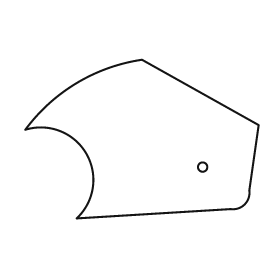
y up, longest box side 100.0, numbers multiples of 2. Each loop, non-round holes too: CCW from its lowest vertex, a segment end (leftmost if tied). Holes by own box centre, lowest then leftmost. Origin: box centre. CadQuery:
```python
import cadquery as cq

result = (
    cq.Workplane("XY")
    .moveTo(-28.0, -34.0)
    .lineTo(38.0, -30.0)
    .threePointArc((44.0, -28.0), (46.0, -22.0))
    .lineTo(50.0, 6.0)
    .lineTo(0.0, 34.0)
    .threePointArc((-28.0, 24.0), (-50.0, 4.0))
    .threePointArc((-24.0, -6.0), (-28.0, -34.0))
    .close()
    .moveTo(26.0, -12.0)
    .circle(2.0)
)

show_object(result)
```